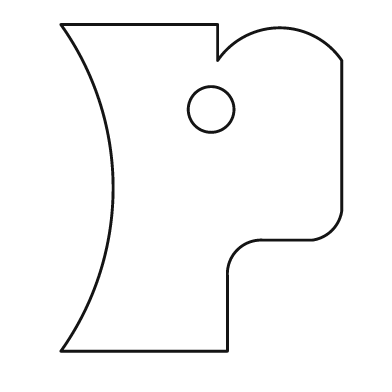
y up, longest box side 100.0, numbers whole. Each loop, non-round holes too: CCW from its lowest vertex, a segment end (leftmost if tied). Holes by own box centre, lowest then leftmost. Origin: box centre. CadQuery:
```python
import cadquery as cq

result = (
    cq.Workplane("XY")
    .moveTo(-43.0, -50.0)
    .lineTo(8.0, -50.0)
    .lineTo(8.0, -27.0)
    .threePointArc((11.0, -19.0), (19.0, -16.0))
    .lineTo(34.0, -16.0)
    .threePointArc((40.0, -13.0), (43.0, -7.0))
    .lineTo(43.0, 39.0)
    .threePointArc((24.0, 49.0), (5.0, 39.0))
    .lineTo(5.0, 50.0)
    .lineTo(-43.0, 50.0)
    .threePointArc((-27.0, 0.0), (-43.0, -50.0))
    .close()
    .moveTo(3.0, 24.0)
    .circle(7.0)
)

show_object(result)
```